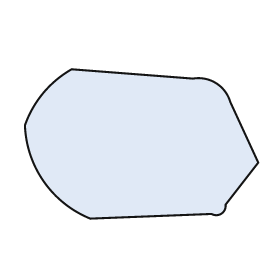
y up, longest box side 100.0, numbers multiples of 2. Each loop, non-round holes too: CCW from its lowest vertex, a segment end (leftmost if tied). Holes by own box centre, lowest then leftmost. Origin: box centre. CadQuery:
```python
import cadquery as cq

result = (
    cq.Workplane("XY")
    .moveTo(-22.0, -32.0)
    .lineTo(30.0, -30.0)
    .threePointArc((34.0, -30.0), (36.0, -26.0))
    .lineTo(50.0, -8.0)
    .lineTo(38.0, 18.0)
    .threePointArc((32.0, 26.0), (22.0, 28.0))
    .lineTo(-30.0, 32.0)
    .threePointArc((-42.0, 22.0), (-50.0, 8.0))
    .threePointArc((-42.0, -16.0), (-22.0, -32.0))
    .close()
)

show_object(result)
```